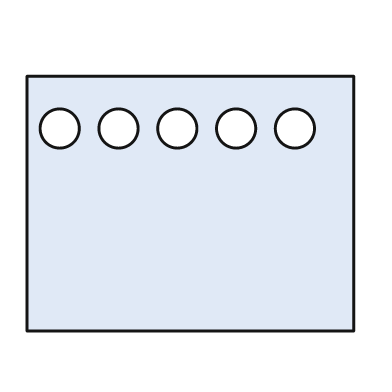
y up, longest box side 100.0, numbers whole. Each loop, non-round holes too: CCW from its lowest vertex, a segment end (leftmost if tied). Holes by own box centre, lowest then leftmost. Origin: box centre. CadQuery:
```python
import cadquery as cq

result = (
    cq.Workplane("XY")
    .moveTo(-50.0, -39.0)
    .lineTo(50.0, -39.0)
    .lineTo(50.0, 39.0)
    .lineTo(-50.0, 39.0)
    .close()
    .moveTo(-40.0, 23.0)
    .circle(6.0)
    .moveTo(-22.0, 23.0)
    .circle(6.0)
    .moveTo(-4.0, 23.0)
    .circle(6.0)
    .moveTo(14.0, 23.0)
    .circle(6.0)
    .moveTo(32.0, 23.0)
    .circle(6.0)
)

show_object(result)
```